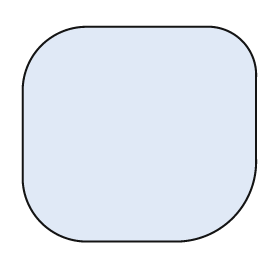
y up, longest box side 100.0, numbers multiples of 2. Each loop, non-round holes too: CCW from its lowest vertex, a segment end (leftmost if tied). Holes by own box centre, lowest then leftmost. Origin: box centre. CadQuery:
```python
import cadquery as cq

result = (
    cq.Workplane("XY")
    .moveTo(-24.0, -46.0)
    .lineTo(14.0, -46.0)
    .threePointArc((40.0, -36.0), (50.0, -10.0))
    .lineTo(50.0, 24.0)
    .threePointArc((44.0, 40.0), (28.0, 46.0))
    .lineTo(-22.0, 46.0)
    .threePointArc((-42.0, 38.0), (-50.0, 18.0))
    .lineTo(-50.0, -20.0)
    .threePointArc((-42.0, -38.0), (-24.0, -46.0))
    .close()
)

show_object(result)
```